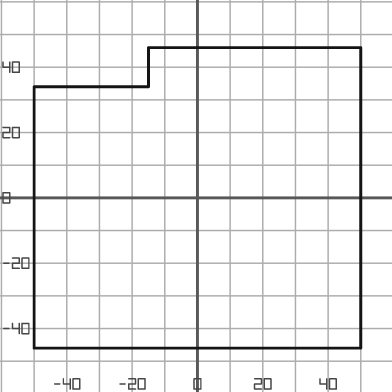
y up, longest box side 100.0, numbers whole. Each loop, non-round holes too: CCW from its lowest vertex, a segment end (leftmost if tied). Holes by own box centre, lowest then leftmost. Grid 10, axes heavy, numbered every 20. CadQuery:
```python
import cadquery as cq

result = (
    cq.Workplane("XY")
    .moveTo(-50.0, -46.0)
    .lineTo(50.0, -46.0)
    .lineTo(50.0, 46.0)
    .lineTo(-15.0, 46.0)
    .lineTo(-15.0, 34.0)
    .lineTo(-50.0, 34.0)
    .close()
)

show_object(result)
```